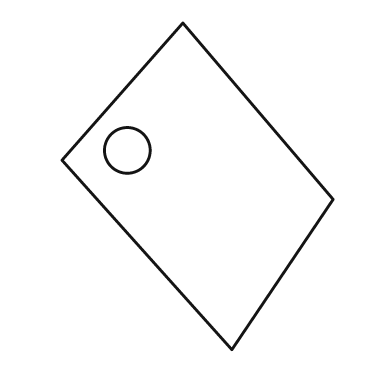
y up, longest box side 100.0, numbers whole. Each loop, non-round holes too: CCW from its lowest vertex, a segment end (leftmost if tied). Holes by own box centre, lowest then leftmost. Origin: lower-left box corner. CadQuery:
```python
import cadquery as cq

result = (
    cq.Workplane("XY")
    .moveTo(52.0, 0.0)
    .lineTo(83.0, 46.0)
    .lineTo(37.0, 100.0)
    .lineTo(0.0, 58.0)
    .close()
    .moveTo(20.0, 61.0)
    .circle(7.0)
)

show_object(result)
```